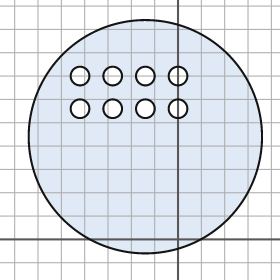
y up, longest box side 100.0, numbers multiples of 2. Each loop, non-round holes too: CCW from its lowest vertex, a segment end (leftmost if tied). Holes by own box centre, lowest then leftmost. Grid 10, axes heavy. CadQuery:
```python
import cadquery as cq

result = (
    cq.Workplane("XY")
    .moveTo(-14.0, 44.0)
    .circle(50.0)
    .moveTo(-42.0, 56.0)
    .circle(4.0)
    .moveTo(-28.0, 56.0)
    .circle(4.0)
    .moveTo(-14.0, 56.0)
    .circle(4.0)
    .moveTo(0.0, 56.0)
    .circle(4.0)
    .moveTo(-42.0, 70.0)
    .circle(4.0)
    .moveTo(-28.0, 70.0)
    .circle(4.0)
    .moveTo(-14.0, 70.0)
    .circle(4.0)
    .moveTo(0.0, 70.0)
    .circle(4.0)
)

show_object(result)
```